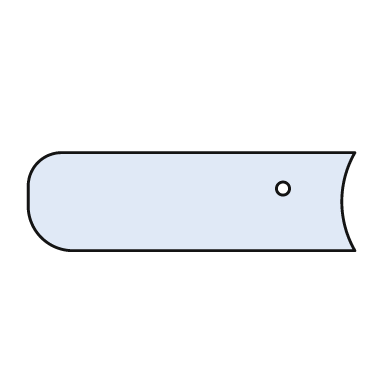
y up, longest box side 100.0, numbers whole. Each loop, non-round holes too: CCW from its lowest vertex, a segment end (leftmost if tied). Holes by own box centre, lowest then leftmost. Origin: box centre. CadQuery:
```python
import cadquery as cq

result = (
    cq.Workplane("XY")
    .moveTo(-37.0, -15.0)
    .lineTo(50.0, -15.0)
    .threePointArc((46.0, 0.0), (50.0, 15.0))
    .lineTo(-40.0, 15.0)
    .threePointArc((-47.0, 12.0), (-50.0, 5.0))
    .lineTo(-50.0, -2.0)
    .threePointArc((-46.0, -11.0), (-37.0, -15.0))
    .close()
    .moveTo(28.0, 4.0)
    .circle(2.0)
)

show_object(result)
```